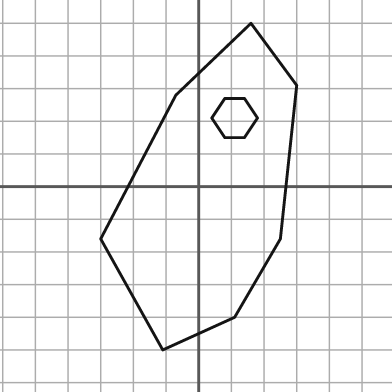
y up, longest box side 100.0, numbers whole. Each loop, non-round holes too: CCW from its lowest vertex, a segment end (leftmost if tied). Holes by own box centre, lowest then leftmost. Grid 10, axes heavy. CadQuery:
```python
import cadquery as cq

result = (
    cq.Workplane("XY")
    .moveTo(-11.0, -50.0)
    .lineTo(11.0, -40.0)
    .lineTo(25.0, -16.0)
    .lineTo(30.0, 31.0)
    .lineTo(16.0, 50.0)
    .lineTo(-7.0, 28.0)
    .lineTo(-30.0, -16.0)
    .close()
    .moveTo(8.0, 15.0)
    .lineTo(14.0, 15.0)
    .lineTo(18.0, 21.0)
    .lineTo(14.0, 27.0)
    .lineTo(8.0, 27.0)
    .lineTo(4.0, 21.0)
    .close()
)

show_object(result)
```